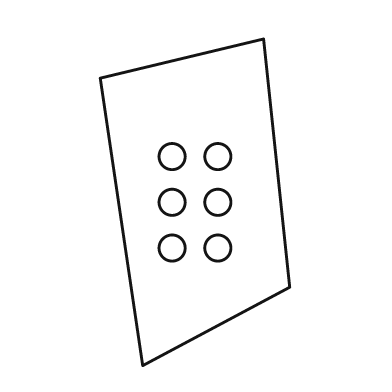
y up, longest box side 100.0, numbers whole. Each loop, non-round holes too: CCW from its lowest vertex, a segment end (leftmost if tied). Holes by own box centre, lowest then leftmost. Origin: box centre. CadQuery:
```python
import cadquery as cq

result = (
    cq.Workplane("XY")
    .moveTo(-16.0, -50.0)
    .lineTo(29.0, -26.0)
    .lineTo(21.0, 50.0)
    .lineTo(-29.0, 38.0)
    .close()
    .moveTo(-7.0, -14.0)
    .circle(4.0)
    .moveTo(7.0, -14.0)
    .circle(4.0)
    .moveTo(-7.0, 0.0)
    .circle(4.0)
    .moveTo(7.0, 0.0)
    .circle(4.0)
    .moveTo(-7.0, 14.0)
    .circle(4.0)
    .moveTo(7.0, 14.0)
    .circle(4.0)
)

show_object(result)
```